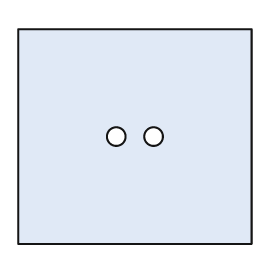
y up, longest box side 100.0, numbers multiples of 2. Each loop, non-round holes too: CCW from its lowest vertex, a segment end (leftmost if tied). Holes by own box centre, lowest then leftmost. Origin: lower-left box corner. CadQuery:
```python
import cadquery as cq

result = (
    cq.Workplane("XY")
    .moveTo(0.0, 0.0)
    .lineTo(100.0, 0.0)
    .lineTo(100.0, 92.0)
    .lineTo(0.0, 92.0)
    .close()
    .moveTo(42.0, 46.0)
    .circle(4.0)
    .moveTo(58.0, 46.0)
    .circle(4.0)
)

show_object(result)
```